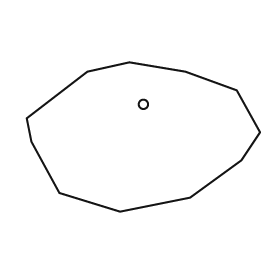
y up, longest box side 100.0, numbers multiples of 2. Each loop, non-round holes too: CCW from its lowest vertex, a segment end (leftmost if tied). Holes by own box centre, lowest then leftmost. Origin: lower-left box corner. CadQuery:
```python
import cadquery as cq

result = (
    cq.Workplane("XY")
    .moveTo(40.0, 0.0)
    .lineTo(70.0, 6.0)
    .lineTo(92.0, 22.0)
    .lineTo(100.0, 34.0)
    .lineTo(90.0, 52.0)
    .lineTo(68.0, 60.0)
    .lineTo(44.0, 64.0)
    .lineTo(26.0, 60.0)
    .lineTo(0.0, 40.0)
    .lineTo(2.0, 30.0)
    .lineTo(14.0, 8.0)
    .close()
    .moveTo(50.0, 46.0)
    .circle(2.0)
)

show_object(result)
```